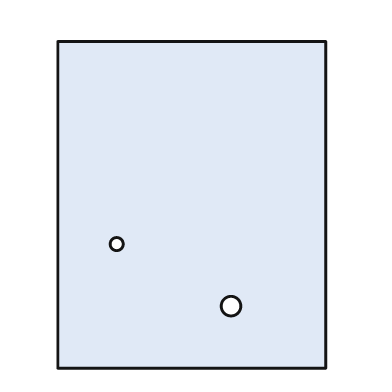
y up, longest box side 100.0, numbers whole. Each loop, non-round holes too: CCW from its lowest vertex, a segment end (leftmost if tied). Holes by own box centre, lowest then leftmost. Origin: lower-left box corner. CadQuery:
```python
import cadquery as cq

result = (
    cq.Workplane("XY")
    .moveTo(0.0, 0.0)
    .lineTo(82.0, 0.0)
    .lineTo(82.0, 100.0)
    .lineTo(0.0, 100.0)
    .close()
    .moveTo(53.0, 19.0)
    .circle(3.0)
    .moveTo(18.0, 38.0)
    .circle(2.0)
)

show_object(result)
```